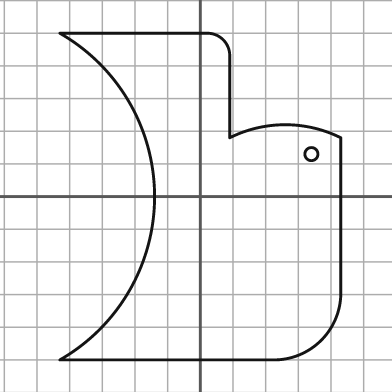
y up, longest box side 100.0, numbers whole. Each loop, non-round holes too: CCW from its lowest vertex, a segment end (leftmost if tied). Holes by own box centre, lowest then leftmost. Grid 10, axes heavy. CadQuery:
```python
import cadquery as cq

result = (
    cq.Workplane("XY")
    .moveTo(-43.0, -50.0)
    .lineTo(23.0, -50.0)
    .threePointArc((37.0, -44.0), (43.0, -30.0))
    .lineTo(43.0, 18.0)
    .threePointArc((26.0, 22.0), (9.0, 18.0))
    .lineTo(9.0, 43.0)
    .threePointArc((7.0, 48.0), (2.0, 50.0))
    .lineTo(-43.0, 50.0)
    .threePointArc((-14.0, 0.0), (-43.0, -50.0))
    .close()
    .moveTo(34.0, 13.0)
    .circle(2.0)
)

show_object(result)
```